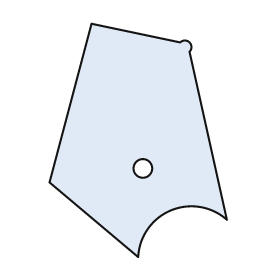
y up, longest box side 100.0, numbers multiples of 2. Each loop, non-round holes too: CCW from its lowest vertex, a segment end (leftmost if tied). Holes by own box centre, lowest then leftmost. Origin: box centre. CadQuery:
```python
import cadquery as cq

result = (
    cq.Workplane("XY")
    .moveTo(0.0, -50.0)
    .threePointArc((14.0, -30.0), (38.0, -34.0))
    .lineTo(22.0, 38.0)
    .threePointArc((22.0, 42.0), (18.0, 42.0))
    .lineTo(-20.0, 50.0)
    .lineTo(-38.0, -18.0)
    .close()
    .moveTo(2.0, -12.0)
    .circle(4.0)
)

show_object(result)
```